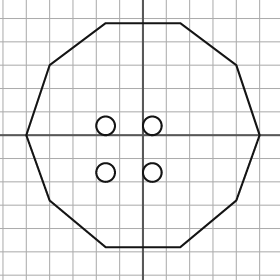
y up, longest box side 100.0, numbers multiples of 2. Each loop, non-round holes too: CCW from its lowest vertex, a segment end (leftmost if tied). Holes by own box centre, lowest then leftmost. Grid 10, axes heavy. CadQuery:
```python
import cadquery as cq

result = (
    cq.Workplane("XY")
    .moveTo(-16.0, -48.0)
    .lineTo(16.0, -48.0)
    .lineTo(40.0, -28.0)
    .lineTo(50.0, 0.0)
    .lineTo(40.0, 30.0)
    .lineTo(16.0, 48.0)
    .lineTo(-16.0, 48.0)
    .lineTo(-40.0, 30.0)
    .lineTo(-50.0, 0.0)
    .lineTo(-40.0, -28.0)
    .close()
    .moveTo(-16.0, -16.0)
    .circle(4.0)
    .moveTo(4.0, -16.0)
    .circle(4.0)
    .moveTo(-16.0, 4.0)
    .circle(4.0)
    .moveTo(4.0, 4.0)
    .circle(4.0)
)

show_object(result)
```